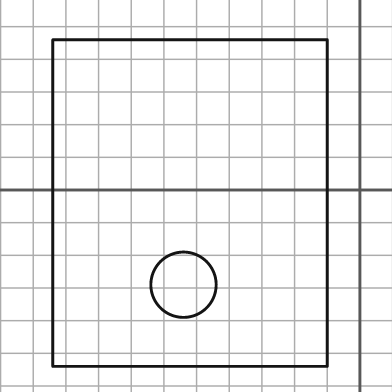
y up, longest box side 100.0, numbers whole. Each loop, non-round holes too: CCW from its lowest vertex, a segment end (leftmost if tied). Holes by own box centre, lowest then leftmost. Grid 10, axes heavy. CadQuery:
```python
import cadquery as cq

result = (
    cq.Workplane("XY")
    .moveTo(-94.0, -54.0)
    .lineTo(-10.0, -54.0)
    .lineTo(-10.0, 46.0)
    .lineTo(-94.0, 46.0)
    .close()
    .moveTo(-54.0, -29.0)
    .circle(10.0)
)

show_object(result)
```